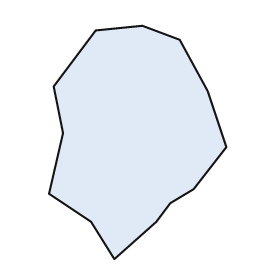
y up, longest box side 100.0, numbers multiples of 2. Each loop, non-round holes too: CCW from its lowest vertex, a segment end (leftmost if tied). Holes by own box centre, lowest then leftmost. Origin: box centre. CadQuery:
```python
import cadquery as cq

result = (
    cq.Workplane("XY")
    .moveTo(-10.0, -50.0)
    .lineTo(8.0, -34.0)
    .lineTo(14.0, -26.0)
    .lineTo(24.0, -20.0)
    .lineTo(38.0, -2.0)
    .lineTo(30.0, 22.0)
    .lineTo(18.0, 44.0)
    .lineTo(2.0, 50.0)
    .lineTo(-18.0, 48.0)
    .lineTo(-36.0, 24.0)
    .lineTo(-32.0, 4.0)
    .lineTo(-38.0, -22.0)
    .lineTo(-20.0, -34.0)
    .close()
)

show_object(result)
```